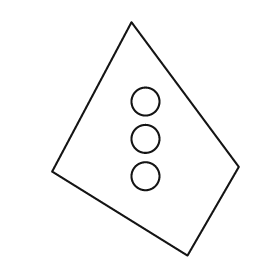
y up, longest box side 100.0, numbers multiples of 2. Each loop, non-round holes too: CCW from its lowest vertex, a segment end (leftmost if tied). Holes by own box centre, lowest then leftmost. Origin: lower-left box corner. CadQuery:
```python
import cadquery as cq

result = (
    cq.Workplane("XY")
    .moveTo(58.0, 0.0)
    .lineTo(80.0, 38.0)
    .lineTo(34.0, 100.0)
    .lineTo(0.0, 36.0)
    .close()
    .moveTo(40.0, 34.0)
    .circle(6.0)
    .moveTo(40.0, 50.0)
    .circle(6.0)
    .moveTo(40.0, 66.0)
    .circle(6.0)
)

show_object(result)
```